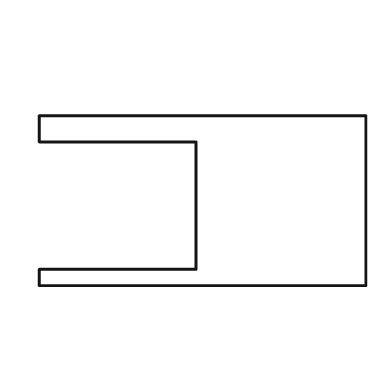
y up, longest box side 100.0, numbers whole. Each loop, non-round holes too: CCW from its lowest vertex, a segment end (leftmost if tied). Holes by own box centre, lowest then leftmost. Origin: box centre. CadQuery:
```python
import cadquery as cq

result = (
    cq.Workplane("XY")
    .moveTo(-50.0, -26.0)
    .lineTo(50.0, -26.0)
    .lineTo(50.0, 26.0)
    .lineTo(-50.0, 26.0)
    .lineTo(-50.0, 18.0)
    .lineTo(-2.0, 18.0)
    .lineTo(-2.0, -21.0)
    .lineTo(-50.0, -21.0)
    .close()
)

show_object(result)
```